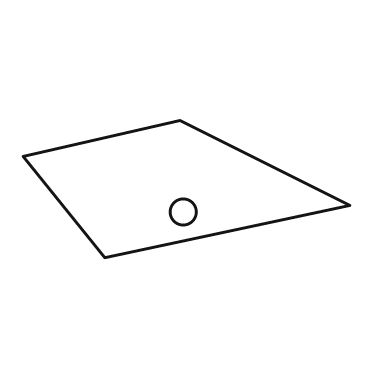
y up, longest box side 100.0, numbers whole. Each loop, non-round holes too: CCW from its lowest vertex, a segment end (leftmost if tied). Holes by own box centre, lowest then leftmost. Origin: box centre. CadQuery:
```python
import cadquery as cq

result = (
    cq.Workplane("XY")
    .moveTo(-25.0, -21.0)
    .lineTo(50.0, -5.0)
    .lineTo(-2.0, 21.0)
    .lineTo(-50.0, 10.0)
    .close()
    .moveTo(-1.0, -7.0)
    .circle(4.0)
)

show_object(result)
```